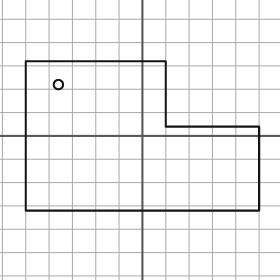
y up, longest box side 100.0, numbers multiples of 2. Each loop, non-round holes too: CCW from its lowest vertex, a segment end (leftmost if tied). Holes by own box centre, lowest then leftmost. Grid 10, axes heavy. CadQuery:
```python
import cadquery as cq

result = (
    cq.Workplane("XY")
    .moveTo(-50.0, -32.0)
    .lineTo(50.0, -32.0)
    .lineTo(50.0, 4.0)
    .lineTo(10.0, 4.0)
    .lineTo(10.0, 32.0)
    .lineTo(-50.0, 32.0)
    .close()
    .moveTo(-36.0, 22.0)
    .circle(2.0)
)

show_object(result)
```